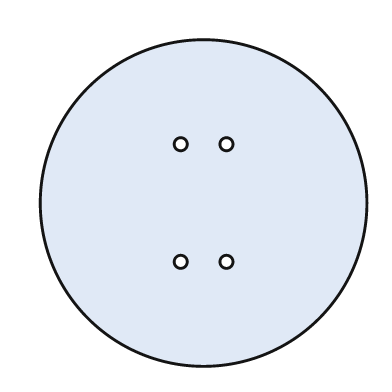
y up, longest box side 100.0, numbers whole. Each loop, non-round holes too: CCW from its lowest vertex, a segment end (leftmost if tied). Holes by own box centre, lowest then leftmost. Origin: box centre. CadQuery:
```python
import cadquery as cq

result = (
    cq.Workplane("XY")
    .moveTo(0.0, 0.0)
    .circle(50.0)
    .moveTo(-7.0, -18.0)
    .circle(2.0)
    .moveTo(7.0, -18.0)
    .circle(2.0)
    .moveTo(-7.0, 18.0)
    .circle(2.0)
    .moveTo(7.0, 18.0)
    .circle(2.0)
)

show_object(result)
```